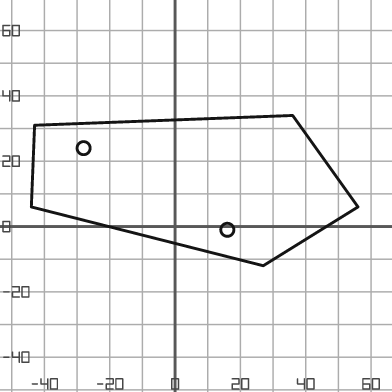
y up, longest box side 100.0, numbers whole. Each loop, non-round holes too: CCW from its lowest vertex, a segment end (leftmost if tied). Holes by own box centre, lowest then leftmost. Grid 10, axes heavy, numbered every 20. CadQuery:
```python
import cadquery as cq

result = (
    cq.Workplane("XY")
    .moveTo(27.0, -12.0)
    .lineTo(56.0, 6.0)
    .lineTo(36.0, 34.0)
    .lineTo(-43.0, 31.0)
    .lineTo(-44.0, 6.0)
    .close()
    .moveTo(16.0, -1.0)
    .circle(2.0)
    .moveTo(-28.0, 24.0)
    .circle(2.0)
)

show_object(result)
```